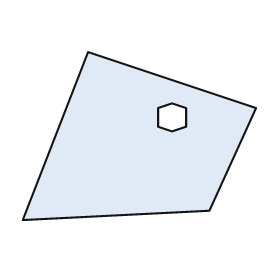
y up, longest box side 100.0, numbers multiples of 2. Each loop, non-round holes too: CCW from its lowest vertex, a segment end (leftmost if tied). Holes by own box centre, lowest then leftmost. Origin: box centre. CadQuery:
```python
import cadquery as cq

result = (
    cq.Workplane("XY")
    .moveTo(-50.0, -36.0)
    .lineTo(30.0, -32.0)
    .lineTo(50.0, 12.0)
    .lineTo(-22.0, 36.0)
    .close()
    .moveTo(14.0, 2.0)
    .lineTo(20.0, 4.0)
    .lineTo(20.0, 12.0)
    .lineTo(14.0, 14.0)
    .lineTo(8.0, 12.0)
    .lineTo(8.0, 4.0)
    .close()
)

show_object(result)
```